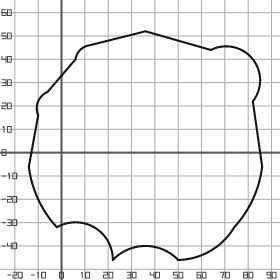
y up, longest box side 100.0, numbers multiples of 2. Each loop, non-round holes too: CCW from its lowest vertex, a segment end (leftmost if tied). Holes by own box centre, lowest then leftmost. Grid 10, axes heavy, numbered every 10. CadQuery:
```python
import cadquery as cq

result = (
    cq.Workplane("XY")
    .moveTo(22.0, -46.0)
    .threePointArc((36.0, -40.0), (50.0, -46.0))
    .threePointArc((64.0, -42.0), (74.0, -32.0))
    .threePointArc((82.0, -20.0), (86.0, -6.0))
    .lineTo(82.0, 22.0)
    .threePointArc((82.0, 40.0), (64.0, 44.0))
    .lineTo(36.0, 52.0)
    .lineTo(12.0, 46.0)
    .threePointArc((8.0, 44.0), (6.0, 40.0))
    .lineTo(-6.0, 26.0)
    .threePointArc((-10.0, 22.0), (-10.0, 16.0))
    .lineTo(-14.0, -6.0)
    .threePointArc((-10.0, -20.0), (-2.0, -32.0))
    .threePointArc((14.0, -32.0), (22.0, -46.0))
    .close()
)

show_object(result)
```